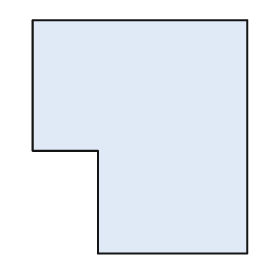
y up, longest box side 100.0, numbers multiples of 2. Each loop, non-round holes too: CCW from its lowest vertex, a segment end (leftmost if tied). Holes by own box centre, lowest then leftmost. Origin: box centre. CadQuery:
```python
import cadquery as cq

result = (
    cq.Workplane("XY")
    .moveTo(-18.0, -50.0)
    .lineTo(46.0, -50.0)
    .lineTo(46.0, 50.0)
    .lineTo(-46.0, 50.0)
    .lineTo(-46.0, -6.0)
    .lineTo(-18.0, -6.0)
    .close()
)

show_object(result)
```